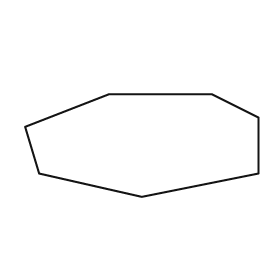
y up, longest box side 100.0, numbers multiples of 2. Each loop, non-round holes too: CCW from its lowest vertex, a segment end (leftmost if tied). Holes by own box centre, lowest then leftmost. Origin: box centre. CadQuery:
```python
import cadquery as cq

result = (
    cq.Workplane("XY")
    .moveTo(0.0, -22.0)
    .lineTo(50.0, -12.0)
    .lineTo(50.0, 12.0)
    .lineTo(30.0, 22.0)
    .lineTo(-14.0, 22.0)
    .lineTo(-50.0, 8.0)
    .lineTo(-44.0, -12.0)
    .close()
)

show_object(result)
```